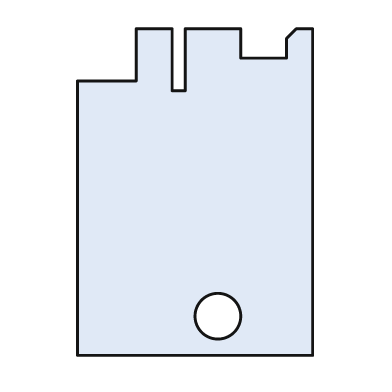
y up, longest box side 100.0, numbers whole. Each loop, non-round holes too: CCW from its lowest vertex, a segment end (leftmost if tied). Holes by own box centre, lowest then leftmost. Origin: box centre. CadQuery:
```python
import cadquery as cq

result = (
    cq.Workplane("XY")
    .moveTo(-36.0, -50.0)
    .lineTo(36.0, -50.0)
    .lineTo(36.0, 50.0)
    .lineTo(31.0, 50.0)
    .lineTo(28.0, 47.0)
    .lineTo(28.0, 41.0)
    .lineTo(14.0, 41.0)
    .lineTo(14.0, 50.0)
    .lineTo(-3.0, 50.0)
    .lineTo(-3.0, 31.0)
    .lineTo(-7.0, 31.0)
    .lineTo(-7.0, 50.0)
    .lineTo(-18.0, 50.0)
    .lineTo(-18.0, 34.0)
    .lineTo(-36.0, 34.0)
    .close()
    .moveTo(7.0, -38.0)
    .circle(7.0)
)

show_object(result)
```